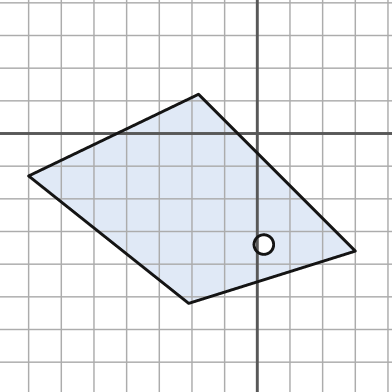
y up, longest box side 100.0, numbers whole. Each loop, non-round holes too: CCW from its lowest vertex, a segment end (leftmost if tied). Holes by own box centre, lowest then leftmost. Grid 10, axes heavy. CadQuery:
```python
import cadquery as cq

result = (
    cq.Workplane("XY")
    .moveTo(-21.0, -52.0)
    .lineTo(30.0, -36.0)
    .lineTo(-18.0, 12.0)
    .lineTo(-70.0, -13.0)
    .close()
    .moveTo(2.0, -34.0)
    .circle(3.0)
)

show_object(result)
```